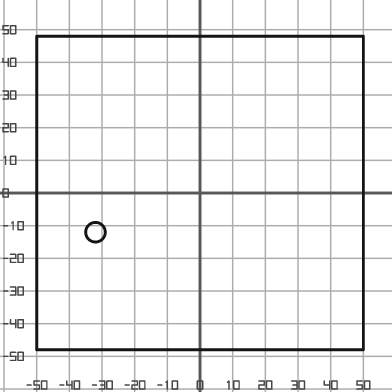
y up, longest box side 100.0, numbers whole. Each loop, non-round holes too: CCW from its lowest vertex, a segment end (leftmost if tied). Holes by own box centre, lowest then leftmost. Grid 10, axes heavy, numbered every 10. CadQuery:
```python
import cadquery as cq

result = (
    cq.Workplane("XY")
    .moveTo(-50.0, -48.0)
    .lineTo(50.0, -48.0)
    .lineTo(50.0, 48.0)
    .lineTo(-50.0, 48.0)
    .close()
    .moveTo(-32.0, -12.0)
    .circle(3.0)
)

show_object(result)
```